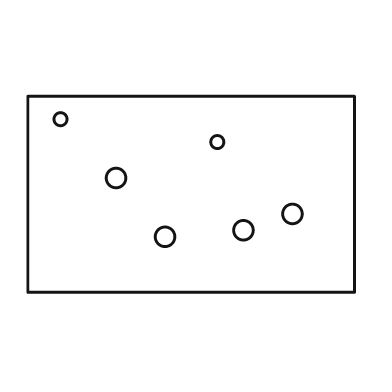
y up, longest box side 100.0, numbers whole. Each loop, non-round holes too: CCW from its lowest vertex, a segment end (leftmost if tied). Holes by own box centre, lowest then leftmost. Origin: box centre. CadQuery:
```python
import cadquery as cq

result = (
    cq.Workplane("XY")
    .moveTo(-50.0, -30.0)
    .lineTo(50.0, -30.0)
    .lineTo(50.0, 30.0)
    .lineTo(-50.0, 30.0)
    .close()
    .moveTo(-8.0, -13.0)
    .circle(3.0)
    .moveTo(16.0, -11.0)
    .circle(3.0)
    .moveTo(31.0, -6.0)
    .circle(3.0)
    .moveTo(-23.0, 5.0)
    .circle(3.0)
    .moveTo(8.0, 16.0)
    .circle(2.0)
    .moveTo(-40.0, 23.0)
    .circle(2.0)
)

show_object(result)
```